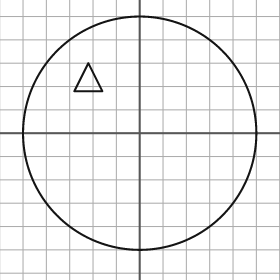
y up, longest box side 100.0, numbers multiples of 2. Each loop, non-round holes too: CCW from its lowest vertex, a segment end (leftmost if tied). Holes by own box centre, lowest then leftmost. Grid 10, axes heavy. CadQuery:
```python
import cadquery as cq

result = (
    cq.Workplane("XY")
    .moveTo(0.0, 0.0)
    .circle(50.0)
    .moveTo(-28.0, 18.0)
    .lineTo(-16.0, 18.0)
    .lineTo(-22.0, 30.0)
    .close()
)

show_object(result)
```